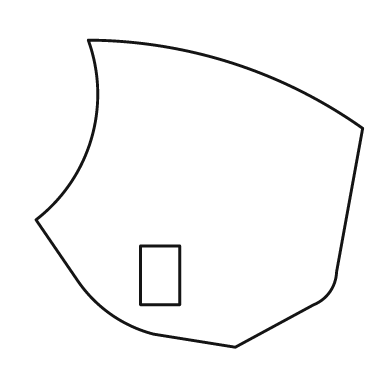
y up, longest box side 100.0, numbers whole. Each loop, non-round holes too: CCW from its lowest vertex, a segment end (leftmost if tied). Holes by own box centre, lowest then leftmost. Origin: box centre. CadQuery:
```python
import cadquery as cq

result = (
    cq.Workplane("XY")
    .moveTo(11.0, -47.0)
    .lineTo(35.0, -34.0)
    .threePointArc((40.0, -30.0), (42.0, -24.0))
    .lineTo(50.0, 20.0)
    .threePointArc((10.0, 40.0), (-34.0, 47.0))
    .threePointArc((-33.0, 17.0), (-50.0, -8.0))
    .lineTo(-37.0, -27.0)
    .threePointArc((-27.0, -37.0), (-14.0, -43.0))
    .close()
    .moveTo(-18.0, -34.0)
    .lineTo(-6.0, -34.0)
    .lineTo(-6.0, -16.0)
    .lineTo(-18.0, -16.0)
    .close()
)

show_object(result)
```